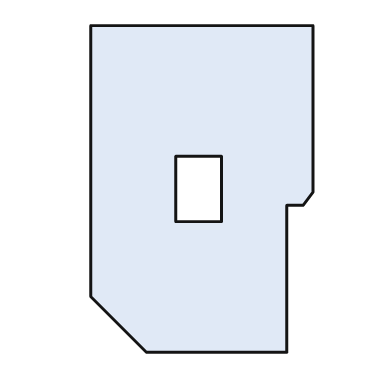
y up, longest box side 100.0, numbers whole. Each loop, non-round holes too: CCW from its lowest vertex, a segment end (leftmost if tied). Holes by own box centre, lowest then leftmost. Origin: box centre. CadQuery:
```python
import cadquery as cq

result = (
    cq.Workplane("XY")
    .moveTo(-17.0, -50.0)
    .lineTo(26.0, -50.0)
    .lineTo(26.0, -5.0)
    .lineTo(31.0, -5.0)
    .lineTo(34.0, -1.0)
    .lineTo(34.0, 50.0)
    .lineTo(-34.0, 50.0)
    .lineTo(-34.0, -33.0)
    .close()
    .moveTo(-8.0, -10.0)
    .lineTo(6.0, -10.0)
    .lineTo(6.0, 10.0)
    .lineTo(-8.0, 10.0)
    .close()
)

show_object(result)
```